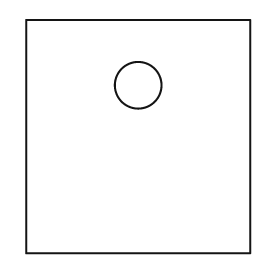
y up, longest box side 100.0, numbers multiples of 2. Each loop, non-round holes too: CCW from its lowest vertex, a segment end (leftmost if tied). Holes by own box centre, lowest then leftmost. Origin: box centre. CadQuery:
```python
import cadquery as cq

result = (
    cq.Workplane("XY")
    .moveTo(-48.0, -50.0)
    .lineTo(48.0, -50.0)
    .lineTo(48.0, 50.0)
    .lineTo(-48.0, 50.0)
    .close()
    .moveTo(0.0, 22.0)
    .circle(10.0)
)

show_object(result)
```